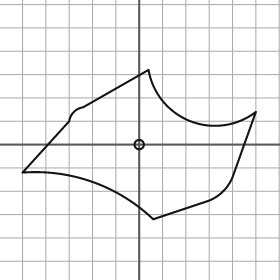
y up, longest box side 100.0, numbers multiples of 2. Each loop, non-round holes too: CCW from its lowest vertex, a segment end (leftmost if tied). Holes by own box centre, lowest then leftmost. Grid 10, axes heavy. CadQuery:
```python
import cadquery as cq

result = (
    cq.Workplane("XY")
    .moveTo(6.0, -32.0)
    .lineTo(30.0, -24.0)
    .threePointArc((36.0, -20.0), (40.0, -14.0))
    .lineTo(50.0, 14.0)
    .threePointArc((22.0, 10.0), (4.0, 32.0))
    .lineTo(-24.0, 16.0)
    .threePointArc((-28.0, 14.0), (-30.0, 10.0))
    .lineTo(-50.0, -12.0)
    .threePointArc((-20.0, -16.0), (6.0, -32.0))
    .close()
    .moveTo(0.0, 0.0)
    .circle(2.0)
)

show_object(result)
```